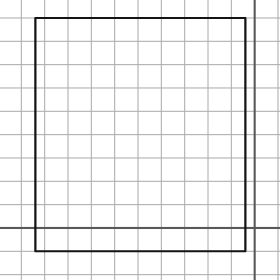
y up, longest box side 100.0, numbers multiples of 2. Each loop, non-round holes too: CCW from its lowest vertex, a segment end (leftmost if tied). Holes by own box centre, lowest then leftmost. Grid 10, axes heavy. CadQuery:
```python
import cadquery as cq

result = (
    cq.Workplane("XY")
    .moveTo(-94.0, -10.0)
    .lineTo(-4.0, -10.0)
    .lineTo(-4.0, 90.0)
    .lineTo(-94.0, 90.0)
    .close()
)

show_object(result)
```